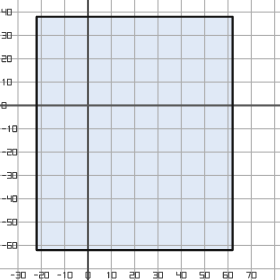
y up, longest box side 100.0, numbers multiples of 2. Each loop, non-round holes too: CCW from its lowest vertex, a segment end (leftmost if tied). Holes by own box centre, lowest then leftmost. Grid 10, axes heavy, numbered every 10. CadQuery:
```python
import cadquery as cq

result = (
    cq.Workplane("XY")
    .moveTo(-22.0, -62.0)
    .lineTo(62.0, -62.0)
    .lineTo(62.0, 38.0)
    .lineTo(-22.0, 38.0)
    .close()
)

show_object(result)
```